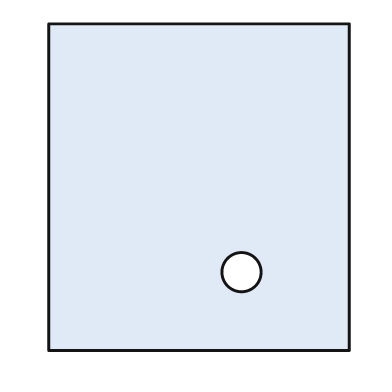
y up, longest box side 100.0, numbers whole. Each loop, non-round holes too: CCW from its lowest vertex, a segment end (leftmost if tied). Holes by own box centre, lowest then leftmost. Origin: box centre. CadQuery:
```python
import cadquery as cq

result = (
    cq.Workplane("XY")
    .moveTo(-46.0, -50.0)
    .lineTo(46.0, -50.0)
    .lineTo(46.0, 50.0)
    .lineTo(-46.0, 50.0)
    .close()
    .moveTo(13.0, -26.0)
    .circle(6.0)
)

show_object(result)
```